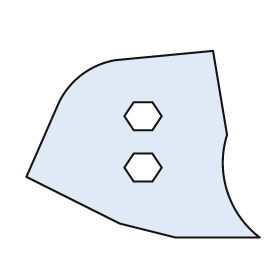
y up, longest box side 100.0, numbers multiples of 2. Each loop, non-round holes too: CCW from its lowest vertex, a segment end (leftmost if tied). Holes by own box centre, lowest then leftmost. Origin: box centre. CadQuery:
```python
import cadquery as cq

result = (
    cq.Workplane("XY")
    .moveTo(14.0, -40.0)
    .lineTo(50.0, -40.0)
    .threePointArc((36.0, -20.0), (36.0, 4.0))
    .lineTo(30.0, 40.0)
    .lineTo(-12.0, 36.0)
    .threePointArc((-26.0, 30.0), (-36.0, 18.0))
    .lineTo(-50.0, -14.0)
    .lineTo(-10.0, -34.0)
    .close()
    .moveTo(-4.0, -16.0)
    .lineTo(4.0, -16.0)
    .lineTo(8.0, -10.0)
    .lineTo(4.0, -4.0)
    .lineTo(-4.0, -4.0)
    .lineTo(-8.0, -10.0)
    .close()
    .moveTo(-4.0, 6.0)
    .lineTo(4.0, 6.0)
    .lineTo(8.0, 12.0)
    .lineTo(4.0, 18.0)
    .lineTo(-4.0, 18.0)
    .lineTo(-8.0, 12.0)
    .close()
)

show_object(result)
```